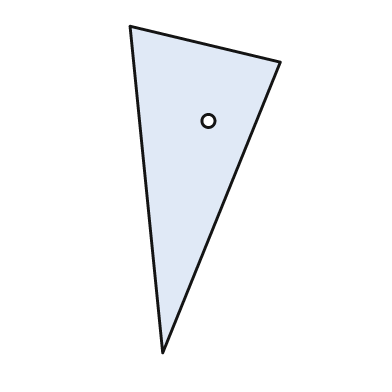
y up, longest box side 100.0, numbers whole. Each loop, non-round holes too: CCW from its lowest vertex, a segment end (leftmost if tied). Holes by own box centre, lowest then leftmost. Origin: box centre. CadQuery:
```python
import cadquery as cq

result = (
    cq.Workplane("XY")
    .moveTo(-13.0, -50.0)
    .lineTo(23.0, 39.0)
    .lineTo(-23.0, 50.0)
    .close()
    .moveTo(1.0, 21.0)
    .circle(2.0)
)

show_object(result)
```